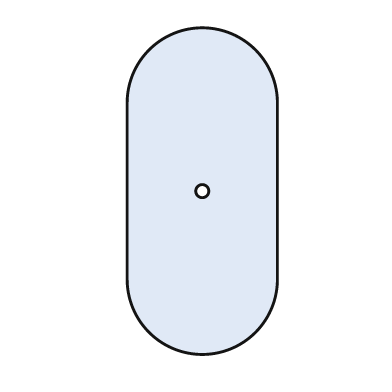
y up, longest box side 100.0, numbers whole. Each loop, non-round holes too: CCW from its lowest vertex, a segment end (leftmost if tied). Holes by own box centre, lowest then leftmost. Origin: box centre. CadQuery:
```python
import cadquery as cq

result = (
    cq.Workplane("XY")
    .moveTo(-23.0, -27.0)
    .threePointArc((0.0, -50.0), (23.0, -27.0))
    .lineTo(23.0, 27.0)
    .threePointArc((0.0, 50.0), (-23.0, 27.0))
    .close()
    .moveTo(0.0, 0.0)
    .circle(2.0)
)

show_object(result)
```